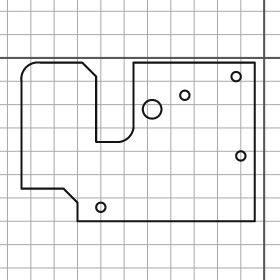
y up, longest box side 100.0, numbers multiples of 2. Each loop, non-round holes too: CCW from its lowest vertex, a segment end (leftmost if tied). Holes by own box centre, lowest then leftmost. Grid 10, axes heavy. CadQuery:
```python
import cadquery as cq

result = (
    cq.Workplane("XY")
    .moveTo(-80.0, -70.0)
    .lineTo(-4.0, -70.0)
    .lineTo(-4.0, -2.0)
    .lineTo(-56.0, -2.0)
    .lineTo(-56.0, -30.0)
    .threePointArc((-58.0, -34.0), (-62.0, -36.0))
    .lineTo(-72.0, -36.0)
    .lineTo(-72.0, -8.0)
    .lineTo(-78.0, -2.0)
    .lineTo(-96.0, -2.0)
    .threePointArc((-102.0, -4.0), (-104.0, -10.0))
    .lineTo(-104.0, -56.0)
    .lineTo(-86.0, -56.0)
    .lineTo(-80.0, -62.0)
    .close()
    .moveTo(-70.0, -64.0)
    .circle(2.0)
    .moveTo(-10.0, -42.0)
    .circle(2.0)
    .moveTo(-48.0, -22.0)
    .circle(4.0)
    .moveTo(-34.0, -16.0)
    .circle(2.0)
    .moveTo(-12.0, -8.0)
    .circle(2.0)
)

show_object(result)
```